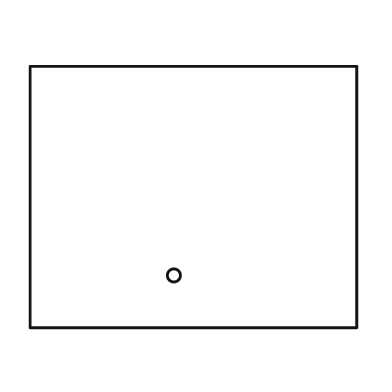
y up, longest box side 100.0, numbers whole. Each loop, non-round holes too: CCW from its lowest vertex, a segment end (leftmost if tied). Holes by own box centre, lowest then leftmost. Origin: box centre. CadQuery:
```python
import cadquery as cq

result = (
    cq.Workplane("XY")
    .moveTo(-50.0, -40.0)
    .lineTo(50.0, -40.0)
    .lineTo(50.0, 40.0)
    .lineTo(-50.0, 40.0)
    .close()
    .moveTo(-6.0, -24.0)
    .circle(2.0)
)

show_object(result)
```